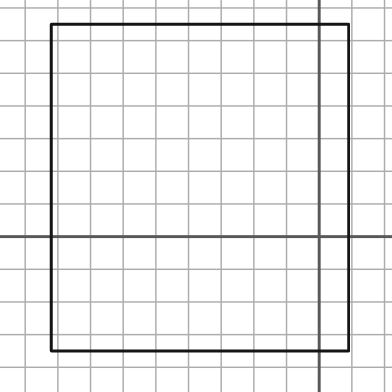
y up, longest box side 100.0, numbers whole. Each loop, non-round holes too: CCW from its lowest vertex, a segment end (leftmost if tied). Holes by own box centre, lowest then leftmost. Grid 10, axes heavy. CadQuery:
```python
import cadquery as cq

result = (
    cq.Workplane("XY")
    .moveTo(-82.0, -35.0)
    .lineTo(9.0, -35.0)
    .lineTo(9.0, 65.0)
    .lineTo(-82.0, 65.0)
    .close()
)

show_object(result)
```